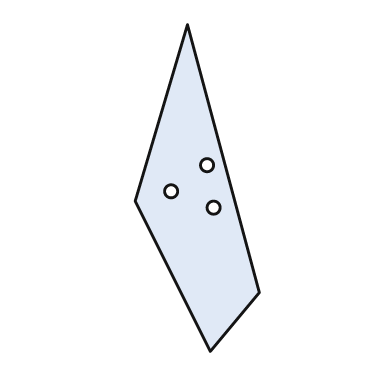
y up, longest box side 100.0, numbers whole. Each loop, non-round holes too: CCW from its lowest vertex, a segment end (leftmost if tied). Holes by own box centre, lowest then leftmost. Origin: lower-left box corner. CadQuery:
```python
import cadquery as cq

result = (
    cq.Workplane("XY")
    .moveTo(23.0, 0.0)
    .lineTo(38.0, 18.0)
    .lineTo(16.0, 100.0)
    .lineTo(0.0, 46.0)
    .close()
    .moveTo(24.0, 44.0)
    .circle(2.0)
    .moveTo(11.0, 49.0)
    .circle(2.0)
    .moveTo(22.0, 57.0)
    .circle(2.0)
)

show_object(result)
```